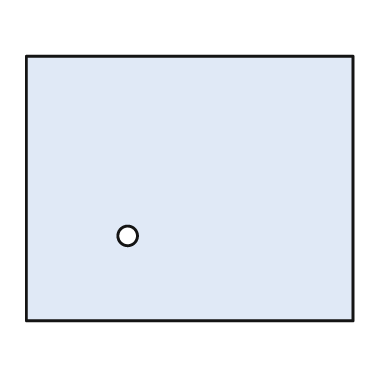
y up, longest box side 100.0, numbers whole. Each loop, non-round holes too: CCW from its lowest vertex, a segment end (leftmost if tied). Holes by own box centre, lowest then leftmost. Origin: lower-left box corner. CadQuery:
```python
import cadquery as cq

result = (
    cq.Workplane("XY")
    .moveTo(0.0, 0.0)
    .lineTo(100.0, 0.0)
    .lineTo(100.0, 81.0)
    .lineTo(0.0, 81.0)
    .close()
    .moveTo(31.0, 26.0)
    .circle(3.0)
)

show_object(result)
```